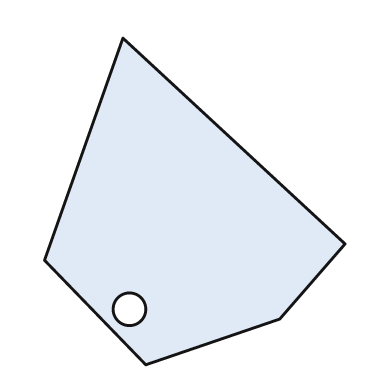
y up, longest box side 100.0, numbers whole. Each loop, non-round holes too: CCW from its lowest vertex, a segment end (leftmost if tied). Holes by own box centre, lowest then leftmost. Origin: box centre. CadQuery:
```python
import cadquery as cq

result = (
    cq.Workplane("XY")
    .moveTo(-15.0, -50.0)
    .lineTo(26.0, -36.0)
    .lineTo(46.0, -13.0)
    .lineTo(-22.0, 50.0)
    .lineTo(-46.0, -18.0)
    .close()
    .moveTo(-20.0, -33.0)
    .circle(5.0)
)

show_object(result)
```